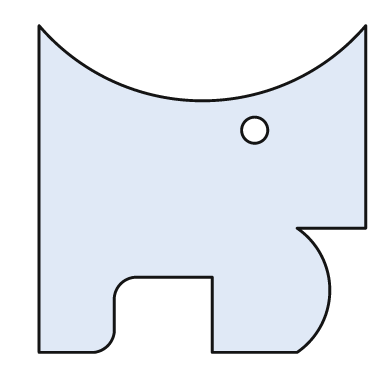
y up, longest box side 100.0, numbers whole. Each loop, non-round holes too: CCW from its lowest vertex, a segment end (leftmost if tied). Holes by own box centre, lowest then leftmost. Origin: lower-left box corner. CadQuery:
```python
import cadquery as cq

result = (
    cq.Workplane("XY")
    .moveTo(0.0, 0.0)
    .lineTo(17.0, 0.0)
    .threePointArc((21.0, 2.0), (23.0, 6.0))
    .lineTo(23.0, 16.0)
    .threePointArc((25.0, 21.0), (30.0, 23.0))
    .lineTo(53.0, 23.0)
    .lineTo(53.0, 0.0)
    .lineTo(79.0, 0.0)
    .threePointArc((89.0, 19.0), (79.0, 38.0))
    .lineTo(100.0, 38.0)
    .lineTo(100.0, 100.0)
    .threePointArc((50.0, 77.0), (0.0, 100.0))
    .close()
    .moveTo(66.0, 68.0)
    .circle(4.0)
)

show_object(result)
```